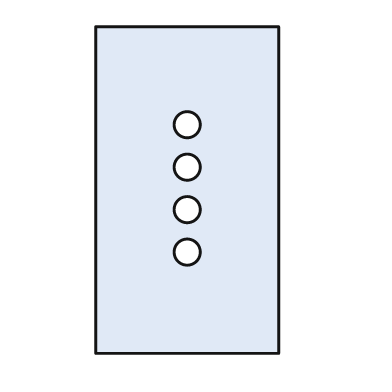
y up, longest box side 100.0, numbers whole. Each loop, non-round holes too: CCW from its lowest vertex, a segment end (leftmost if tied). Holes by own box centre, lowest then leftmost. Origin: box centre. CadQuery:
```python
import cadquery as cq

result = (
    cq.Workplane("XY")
    .moveTo(-28.0, -50.0)
    .lineTo(28.0, -50.0)
    .lineTo(28.0, 50.0)
    .lineTo(-28.0, 50.0)
    .close()
    .moveTo(0.0, -19.0)
    .circle(4.0)
    .moveTo(0.0, -6.0)
    .circle(4.0)
    .moveTo(0.0, 7.0)
    .circle(4.0)
    .moveTo(0.0, 20.0)
    .circle(4.0)
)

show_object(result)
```